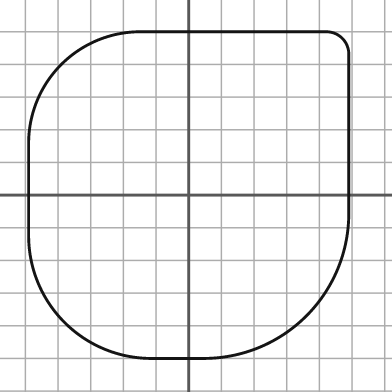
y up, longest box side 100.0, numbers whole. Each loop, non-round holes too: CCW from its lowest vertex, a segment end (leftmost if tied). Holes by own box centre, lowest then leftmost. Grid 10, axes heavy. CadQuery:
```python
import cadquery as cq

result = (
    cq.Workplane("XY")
    .moveTo(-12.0, -50.0)
    .lineTo(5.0, -50.0)
    .threePointArc((36.0, -37.0), (49.0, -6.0))
    .lineTo(49.0, 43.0)
    .threePointArc((47.0, 48.0), (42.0, 50.0))
    .lineTo(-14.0, 50.0)
    .threePointArc((-39.0, 40.0), (-49.0, 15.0))
    .lineTo(-49.0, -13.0)
    .threePointArc((-38.0, -39.0), (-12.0, -50.0))
    .close()
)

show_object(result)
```